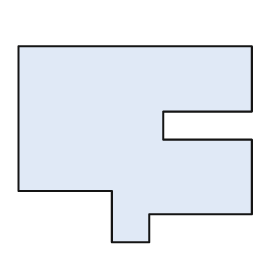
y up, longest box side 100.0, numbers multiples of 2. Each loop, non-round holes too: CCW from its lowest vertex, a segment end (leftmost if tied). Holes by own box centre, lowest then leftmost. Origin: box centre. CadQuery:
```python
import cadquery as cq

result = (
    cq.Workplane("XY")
    .moveTo(-10.0, -42.0)
    .lineTo(6.0, -42.0)
    .lineTo(6.0, -30.0)
    .lineTo(50.0, -30.0)
    .lineTo(50.0, 2.0)
    .lineTo(12.0, 2.0)
    .lineTo(12.0, 14.0)
    .lineTo(50.0, 14.0)
    .lineTo(50.0, 42.0)
    .lineTo(-50.0, 42.0)
    .lineTo(-50.0, -20.0)
    .lineTo(-10.0, -20.0)
    .close()
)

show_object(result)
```